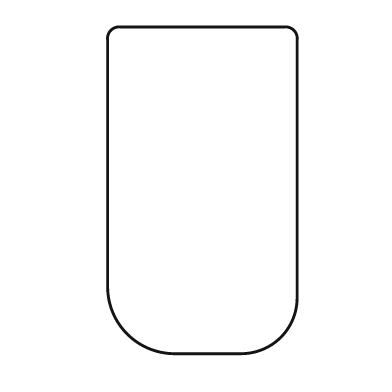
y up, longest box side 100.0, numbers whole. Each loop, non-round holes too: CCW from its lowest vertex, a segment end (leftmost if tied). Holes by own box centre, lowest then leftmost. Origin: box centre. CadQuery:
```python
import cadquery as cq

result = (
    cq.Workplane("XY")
    .moveTo(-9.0, -50.0)
    .lineTo(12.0, -50.0)
    .threePointArc((24.0, -45.0), (29.0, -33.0))
    .lineTo(29.0, 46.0)
    .threePointArc((28.0, 49.0), (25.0, 50.0))
    .lineTo(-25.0, 50.0)
    .threePointArc((-28.0, 49.0), (-29.0, 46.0))
    .lineTo(-29.0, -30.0)
    .threePointArc((-23.0, -44.0), (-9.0, -50.0))
    .close()
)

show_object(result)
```